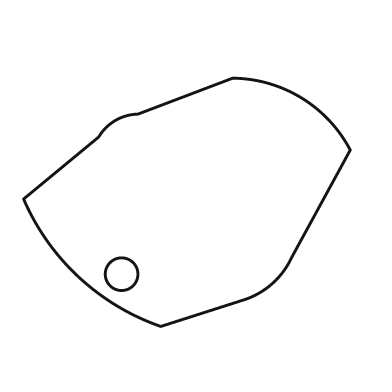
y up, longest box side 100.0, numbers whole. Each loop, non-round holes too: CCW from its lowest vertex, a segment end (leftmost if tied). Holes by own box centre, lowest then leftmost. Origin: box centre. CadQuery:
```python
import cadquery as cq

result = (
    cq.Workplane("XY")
    .moveTo(-8.0, -38.0)
    .lineTo(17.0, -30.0)
    .threePointArc((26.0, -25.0), (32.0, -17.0))
    .lineTo(50.0, 16.0)
    .threePointArc((35.0, 32.0), (14.0, 38.0))
    .lineTo(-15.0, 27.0)
    .threePointArc((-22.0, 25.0), (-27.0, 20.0))
    .lineTo(-50.0, 1.0)
    .threePointArc((-33.0, -23.0), (-8.0, -38.0))
    .close()
    .moveTo(-20.0, -22.0)
    .circle(5.0)
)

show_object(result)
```